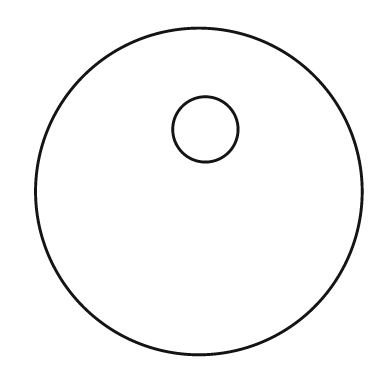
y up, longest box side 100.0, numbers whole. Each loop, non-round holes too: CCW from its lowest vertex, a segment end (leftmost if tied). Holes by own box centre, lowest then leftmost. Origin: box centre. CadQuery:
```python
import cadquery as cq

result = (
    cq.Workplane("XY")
    .moveTo(0.0, 0.0)
    .circle(50.0)
    .moveTo(2.0, 19.0)
    .circle(10.0)
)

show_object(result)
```